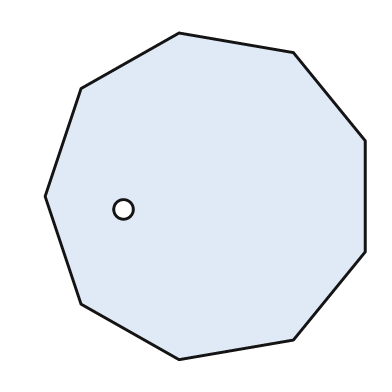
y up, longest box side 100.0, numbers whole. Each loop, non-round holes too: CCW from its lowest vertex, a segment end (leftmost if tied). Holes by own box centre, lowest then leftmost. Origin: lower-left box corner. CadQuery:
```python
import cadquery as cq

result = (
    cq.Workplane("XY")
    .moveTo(41.0, 0.0)
    .lineTo(76.0, 6.0)
    .lineTo(98.0, 33.0)
    .lineTo(98.0, 67.0)
    .lineTo(76.0, 94.0)
    .lineTo(41.0, 100.0)
    .lineTo(11.0, 83.0)
    .lineTo(0.0, 50.0)
    .lineTo(11.0, 17.0)
    .close()
    .moveTo(24.0, 46.0)
    .circle(3.0)
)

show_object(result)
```